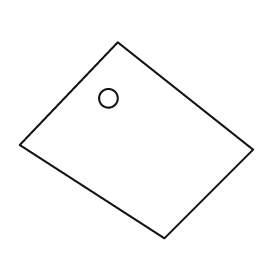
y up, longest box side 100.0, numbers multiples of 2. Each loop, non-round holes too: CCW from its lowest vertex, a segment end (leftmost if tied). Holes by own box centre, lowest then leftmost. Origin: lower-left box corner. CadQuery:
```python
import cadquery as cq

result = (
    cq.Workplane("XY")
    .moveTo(62.0, 0.0)
    .lineTo(100.0, 38.0)
    .lineTo(42.0, 84.0)
    .lineTo(0.0, 40.0)
    .close()
    .moveTo(38.0, 60.0)
    .circle(4.0)
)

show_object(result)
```